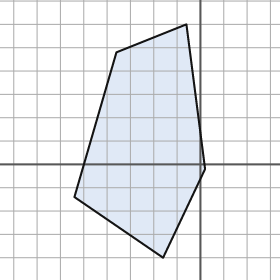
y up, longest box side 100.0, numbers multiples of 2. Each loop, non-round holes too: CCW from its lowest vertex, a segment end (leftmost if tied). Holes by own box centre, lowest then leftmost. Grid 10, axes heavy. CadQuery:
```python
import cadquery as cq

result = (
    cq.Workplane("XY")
    .moveTo(-16.0, -40.0)
    .lineTo(2.0, -2.0)
    .lineTo(-6.0, 60.0)
    .lineTo(-36.0, 48.0)
    .lineTo(-54.0, -14.0)
    .close()
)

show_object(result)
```